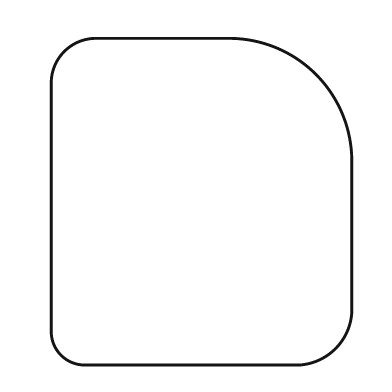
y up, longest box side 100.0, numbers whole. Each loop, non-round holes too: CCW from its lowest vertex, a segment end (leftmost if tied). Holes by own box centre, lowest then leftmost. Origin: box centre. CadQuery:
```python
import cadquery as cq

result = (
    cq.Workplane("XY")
    .moveTo(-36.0, -50.0)
    .lineTo(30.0, -50.0)
    .threePointArc((41.0, -45.0), (46.0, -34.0))
    .lineTo(46.0, 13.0)
    .threePointArc((35.0, 39.0), (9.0, 50.0))
    .lineTo(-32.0, 50.0)
    .threePointArc((-42.0, 46.0), (-46.0, 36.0))
    .lineTo(-46.0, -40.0)
    .threePointArc((-43.0, -47.0), (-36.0, -50.0))
    .close()
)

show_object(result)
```